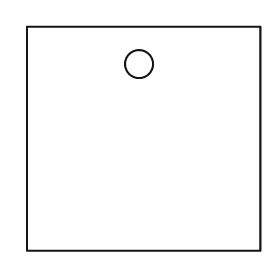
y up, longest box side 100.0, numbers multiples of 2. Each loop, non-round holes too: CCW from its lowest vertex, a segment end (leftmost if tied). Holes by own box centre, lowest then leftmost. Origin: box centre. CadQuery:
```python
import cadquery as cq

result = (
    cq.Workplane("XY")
    .moveTo(-50.0, -48.0)
    .lineTo(50.0, -48.0)
    .lineTo(50.0, 48.0)
    .lineTo(-50.0, 48.0)
    .close()
    .moveTo(-2.0, 32.0)
    .circle(6.0)
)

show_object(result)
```